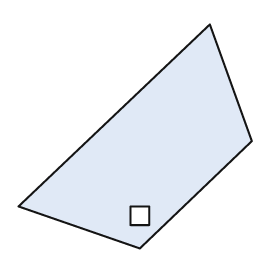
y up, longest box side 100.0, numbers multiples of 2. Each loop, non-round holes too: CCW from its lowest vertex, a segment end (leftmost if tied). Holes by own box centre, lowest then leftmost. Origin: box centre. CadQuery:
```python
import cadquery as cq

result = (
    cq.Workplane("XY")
    .moveTo(2.0, -48.0)
    .lineTo(50.0, -2.0)
    .lineTo(32.0, 48.0)
    .lineTo(-50.0, -30.0)
    .close()
    .moveTo(-2.0, -38.0)
    .lineTo(6.0, -38.0)
    .lineTo(6.0, -30.0)
    .lineTo(-2.0, -30.0)
    .close()
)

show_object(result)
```